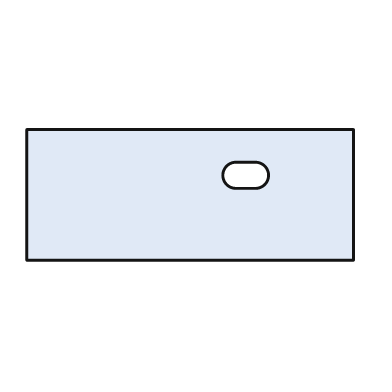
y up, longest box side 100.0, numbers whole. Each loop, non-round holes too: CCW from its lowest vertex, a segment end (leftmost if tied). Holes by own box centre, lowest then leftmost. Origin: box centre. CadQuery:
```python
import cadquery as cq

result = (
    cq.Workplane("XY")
    .moveTo(-50.0, -20.0)
    .lineTo(50.0, -20.0)
    .lineTo(50.0, 20.0)
    .lineTo(-50.0, 20.0)
    .close()
    .moveTo(14.0, 2.0)
    .lineTo(20.0, 2.0)
    .threePointArc((24.0, 6.0), (20.0, 10.0))
    .lineTo(14.0, 10.0)
    .threePointArc((10.0, 6.0), (14.0, 2.0))
    .close()
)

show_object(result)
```